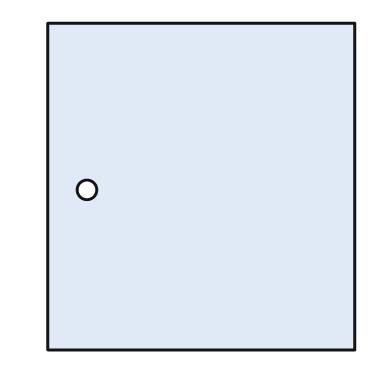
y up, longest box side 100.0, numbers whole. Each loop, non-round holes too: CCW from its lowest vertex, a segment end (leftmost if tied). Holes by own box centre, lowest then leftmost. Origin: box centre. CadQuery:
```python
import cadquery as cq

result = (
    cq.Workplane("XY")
    .moveTo(-47.0, -50.0)
    .lineTo(47.0, -50.0)
    .lineTo(47.0, 50.0)
    .lineTo(-47.0, 50.0)
    .close()
    .moveTo(-35.0, -1.0)
    .circle(3.0)
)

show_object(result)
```